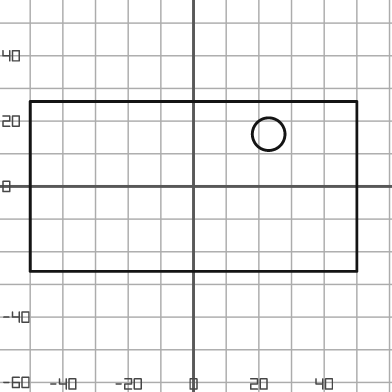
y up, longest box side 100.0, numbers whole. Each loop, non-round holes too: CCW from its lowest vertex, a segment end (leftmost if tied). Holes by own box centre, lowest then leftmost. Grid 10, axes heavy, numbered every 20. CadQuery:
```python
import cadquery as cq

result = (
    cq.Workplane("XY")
    .moveTo(-50.0, -26.0)
    .lineTo(50.0, -26.0)
    .lineTo(50.0, 26.0)
    .lineTo(-50.0, 26.0)
    .close()
    .moveTo(23.0, 16.0)
    .circle(5.0)
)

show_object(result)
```